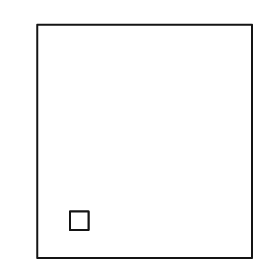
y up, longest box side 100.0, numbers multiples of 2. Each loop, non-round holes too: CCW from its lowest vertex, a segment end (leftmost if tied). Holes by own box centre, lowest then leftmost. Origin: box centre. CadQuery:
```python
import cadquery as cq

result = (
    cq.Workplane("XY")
    .moveTo(-46.0, -50.0)
    .lineTo(46.0, -50.0)
    .lineTo(46.0, 50.0)
    .lineTo(-46.0, 50.0)
    .close()
    .moveTo(-32.0, -38.0)
    .lineTo(-24.0, -38.0)
    .lineTo(-24.0, -30.0)
    .lineTo(-32.0, -30.0)
    .close()
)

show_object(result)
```